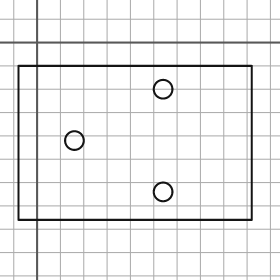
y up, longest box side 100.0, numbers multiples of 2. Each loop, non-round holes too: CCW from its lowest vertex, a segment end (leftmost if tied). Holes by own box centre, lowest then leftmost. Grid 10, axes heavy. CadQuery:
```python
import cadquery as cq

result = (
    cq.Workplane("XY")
    .moveTo(-8.0, -76.0)
    .lineTo(92.0, -76.0)
    .lineTo(92.0, -10.0)
    .lineTo(-8.0, -10.0)
    .close()
    .moveTo(54.0, -64.0)
    .circle(4.0)
    .moveTo(16.0, -42.0)
    .circle(4.0)
    .moveTo(54.0, -20.0)
    .circle(4.0)
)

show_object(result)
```